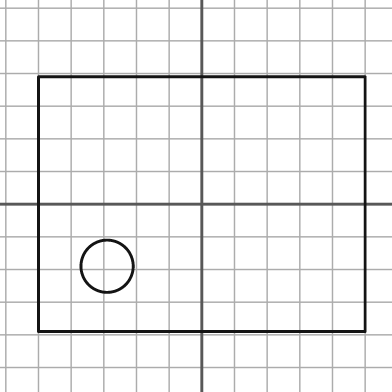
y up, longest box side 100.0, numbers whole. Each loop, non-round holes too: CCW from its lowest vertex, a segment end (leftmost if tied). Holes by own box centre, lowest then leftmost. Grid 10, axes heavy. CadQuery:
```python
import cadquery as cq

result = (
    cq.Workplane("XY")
    .moveTo(-50.0, -39.0)
    .lineTo(50.0, -39.0)
    .lineTo(50.0, 39.0)
    .lineTo(-50.0, 39.0)
    .close()
    .moveTo(-29.0, -19.0)
    .circle(8.0)
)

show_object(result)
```